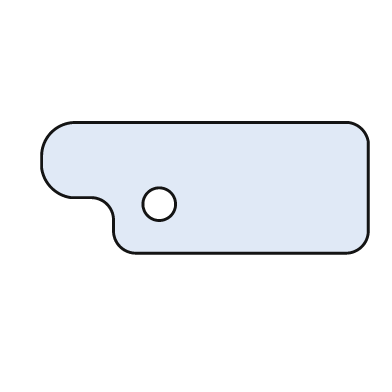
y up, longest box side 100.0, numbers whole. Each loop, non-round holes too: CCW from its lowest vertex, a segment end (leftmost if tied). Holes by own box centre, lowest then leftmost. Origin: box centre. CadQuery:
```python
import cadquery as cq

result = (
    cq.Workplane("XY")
    .moveTo(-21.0, -20.0)
    .lineTo(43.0, -20.0)
    .threePointArc((48.0, -18.0), (50.0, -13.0))
    .lineTo(50.0, 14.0)
    .threePointArc((48.0, 18.0), (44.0, 20.0))
    .lineTo(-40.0, 20.0)
    .threePointArc((-47.0, 17.0), (-50.0, 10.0))
    .lineTo(-50.0, 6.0)
    .threePointArc((-47.0, 0.0), (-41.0, -3.0))
    .lineTo(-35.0, -3.0)
    .threePointArc((-30.0, -5.0), (-28.0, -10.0))
    .lineTo(-28.0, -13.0)
    .threePointArc((-26.0, -18.0), (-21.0, -20.0))
    .close()
    .moveTo(-14.0, -5.0)
    .circle(5.0)
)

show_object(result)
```